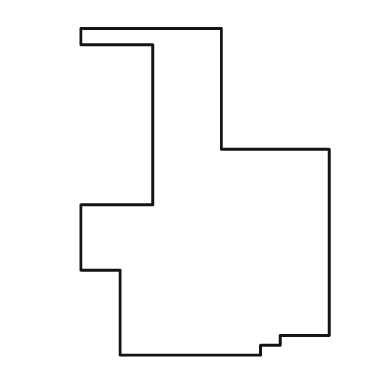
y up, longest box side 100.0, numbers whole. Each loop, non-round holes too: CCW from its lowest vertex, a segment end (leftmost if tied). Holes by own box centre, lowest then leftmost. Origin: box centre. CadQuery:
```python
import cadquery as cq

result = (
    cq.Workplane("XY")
    .moveTo(-26.0, -50.0)
    .lineTo(17.0, -50.0)
    .lineTo(17.0, -47.0)
    .lineTo(23.0, -47.0)
    .lineTo(23.0, -44.0)
    .lineTo(38.0, -44.0)
    .lineTo(38.0, 13.0)
    .lineTo(5.0, 13.0)
    .lineTo(5.0, 50.0)
    .lineTo(-38.0, 50.0)
    .lineTo(-38.0, 45.0)
    .lineTo(-16.0, 45.0)
    .lineTo(-16.0, -4.0)
    .lineTo(-38.0, -4.0)
    .lineTo(-38.0, -24.0)
    .lineTo(-26.0, -24.0)
    .close()
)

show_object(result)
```